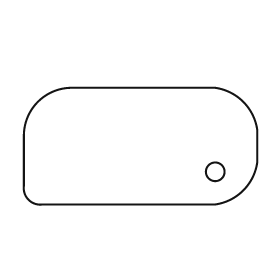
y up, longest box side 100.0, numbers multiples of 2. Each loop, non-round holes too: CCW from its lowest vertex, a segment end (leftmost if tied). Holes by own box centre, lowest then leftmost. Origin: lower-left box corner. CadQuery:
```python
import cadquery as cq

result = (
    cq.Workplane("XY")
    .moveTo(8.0, 0.0)
    .lineTo(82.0, 0.0)
    .threePointArc((94.0, 6.0), (100.0, 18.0))
    .lineTo(100.0, 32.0)
    .threePointArc((94.0, 44.0), (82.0, 50.0))
    .lineTo(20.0, 50.0)
    .threePointArc((6.0, 44.0), (0.0, 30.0))
    .lineTo(0.0, 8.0)
    .threePointArc((2.0, 2.0), (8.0, 0.0))
    .close()
    .moveTo(82.0, 14.0)
    .circle(4.0)
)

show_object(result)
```